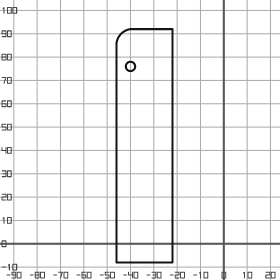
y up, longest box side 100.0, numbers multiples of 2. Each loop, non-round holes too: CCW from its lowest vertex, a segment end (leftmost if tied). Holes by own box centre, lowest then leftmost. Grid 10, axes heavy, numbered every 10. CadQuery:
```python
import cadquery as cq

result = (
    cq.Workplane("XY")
    .moveTo(-46.0, -8.0)
    .lineTo(-22.0, -8.0)
    .lineTo(-22.0, 92.0)
    .lineTo(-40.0, 92.0)
    .threePointArc((-44.0, 90.0), (-46.0, 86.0))
    .close()
    .moveTo(-40.0, 76.0)
    .circle(2.0)
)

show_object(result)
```